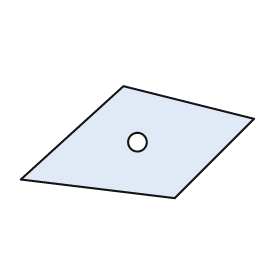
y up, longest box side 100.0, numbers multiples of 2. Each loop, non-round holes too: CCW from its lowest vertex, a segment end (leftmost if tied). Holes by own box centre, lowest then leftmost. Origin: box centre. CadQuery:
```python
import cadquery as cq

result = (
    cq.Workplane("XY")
    .moveTo(16.0, -24.0)
    .lineTo(50.0, 10.0)
    .lineTo(-6.0, 24.0)
    .lineTo(-50.0, -16.0)
    .close()
    .moveTo(0.0, 0.0)
    .circle(4.0)
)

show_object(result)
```